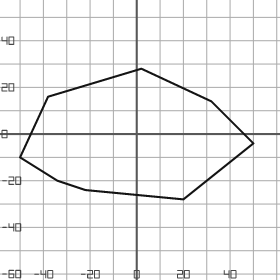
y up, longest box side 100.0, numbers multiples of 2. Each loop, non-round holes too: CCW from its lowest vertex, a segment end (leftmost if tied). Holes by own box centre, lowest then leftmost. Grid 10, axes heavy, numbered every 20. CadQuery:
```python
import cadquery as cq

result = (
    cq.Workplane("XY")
    .moveTo(20.0, -28.0)
    .lineTo(50.0, -4.0)
    .lineTo(32.0, 14.0)
    .lineTo(2.0, 28.0)
    .lineTo(-38.0, 16.0)
    .lineTo(-50.0, -10.0)
    .lineTo(-34.0, -20.0)
    .lineTo(-22.0, -24.0)
    .close()
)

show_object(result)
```